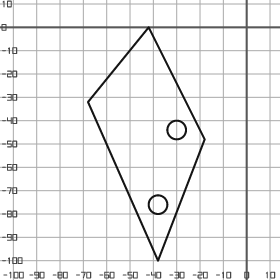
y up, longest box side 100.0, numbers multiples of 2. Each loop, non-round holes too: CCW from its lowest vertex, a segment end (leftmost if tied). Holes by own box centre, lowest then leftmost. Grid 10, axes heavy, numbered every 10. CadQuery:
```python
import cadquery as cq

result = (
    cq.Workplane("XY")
    .moveTo(-38.0, -100.0)
    .lineTo(-18.0, -48.0)
    .lineTo(-42.0, 0.0)
    .lineTo(-68.0, -32.0)
    .close()
    .moveTo(-38.0, -76.0)
    .circle(4.0)
    .moveTo(-30.0, -44.0)
    .circle(4.0)
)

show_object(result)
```